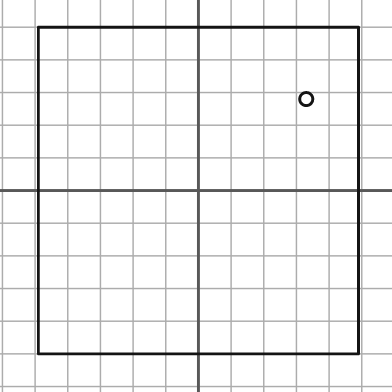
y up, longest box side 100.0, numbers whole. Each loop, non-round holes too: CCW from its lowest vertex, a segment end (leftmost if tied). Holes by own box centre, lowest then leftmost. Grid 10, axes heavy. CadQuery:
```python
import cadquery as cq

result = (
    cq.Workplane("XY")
    .moveTo(-49.0, -50.0)
    .lineTo(49.0, -50.0)
    .lineTo(49.0, 50.0)
    .lineTo(-49.0, 50.0)
    .close()
    .moveTo(33.0, 28.0)
    .circle(2.0)
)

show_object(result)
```